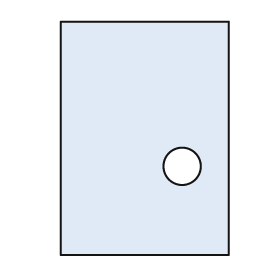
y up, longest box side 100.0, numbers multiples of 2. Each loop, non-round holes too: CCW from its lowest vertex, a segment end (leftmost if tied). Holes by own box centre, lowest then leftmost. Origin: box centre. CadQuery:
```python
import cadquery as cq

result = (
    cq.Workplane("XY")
    .moveTo(-36.0, -50.0)
    .lineTo(36.0, -50.0)
    .lineTo(36.0, 50.0)
    .lineTo(-36.0, 50.0)
    .close()
    .moveTo(16.0, -12.0)
    .circle(8.0)
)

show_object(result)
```